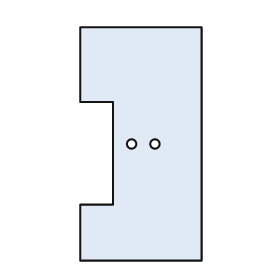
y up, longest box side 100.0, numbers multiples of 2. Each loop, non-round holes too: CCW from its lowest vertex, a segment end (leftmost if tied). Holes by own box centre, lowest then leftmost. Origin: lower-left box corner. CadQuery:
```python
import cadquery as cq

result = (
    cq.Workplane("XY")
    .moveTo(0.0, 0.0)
    .lineTo(52.0, 0.0)
    .lineTo(52.0, 100.0)
    .lineTo(0.0, 100.0)
    .lineTo(0.0, 68.0)
    .lineTo(14.0, 68.0)
    .lineTo(14.0, 24.0)
    .lineTo(0.0, 24.0)
    .close()
    .moveTo(22.0, 50.0)
    .circle(2.0)
    .moveTo(32.0, 50.0)
    .circle(2.0)
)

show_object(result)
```